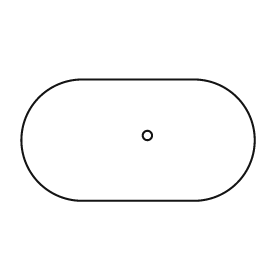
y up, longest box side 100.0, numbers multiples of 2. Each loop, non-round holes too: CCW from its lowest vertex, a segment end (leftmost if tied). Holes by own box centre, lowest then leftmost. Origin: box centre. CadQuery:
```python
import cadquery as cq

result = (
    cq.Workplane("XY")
    .moveTo(-24.0, -26.0)
    .lineTo(24.0, -26.0)
    .threePointArc((50.0, 0.0), (24.0, 26.0))
    .lineTo(-24.0, 26.0)
    .threePointArc((-50.0, 0.0), (-24.0, -26.0))
    .close()
    .moveTo(4.0, 2.0)
    .circle(2.0)
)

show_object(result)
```